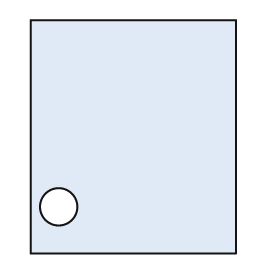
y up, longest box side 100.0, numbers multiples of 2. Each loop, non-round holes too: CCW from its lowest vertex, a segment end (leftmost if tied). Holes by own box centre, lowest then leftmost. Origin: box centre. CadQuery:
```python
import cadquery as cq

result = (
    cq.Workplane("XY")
    .moveTo(-44.0, -50.0)
    .lineTo(44.0, -50.0)
    .lineTo(44.0, 50.0)
    .lineTo(-44.0, 50.0)
    .close()
    .moveTo(-32.0, -30.0)
    .circle(8.0)
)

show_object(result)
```